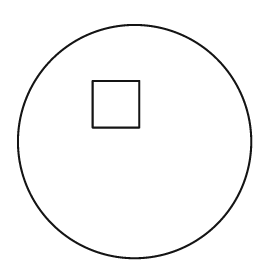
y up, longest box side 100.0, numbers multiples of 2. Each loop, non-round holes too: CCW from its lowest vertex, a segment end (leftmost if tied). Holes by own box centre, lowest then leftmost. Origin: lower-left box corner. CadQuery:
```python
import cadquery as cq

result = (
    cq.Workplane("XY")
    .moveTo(50.0, 50.0)
    .circle(50.0)
    .moveTo(32.0, 56.0)
    .lineTo(52.0, 56.0)
    .lineTo(52.0, 76.0)
    .lineTo(32.0, 76.0)
    .close()
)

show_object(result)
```